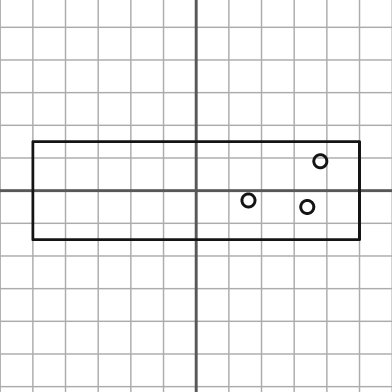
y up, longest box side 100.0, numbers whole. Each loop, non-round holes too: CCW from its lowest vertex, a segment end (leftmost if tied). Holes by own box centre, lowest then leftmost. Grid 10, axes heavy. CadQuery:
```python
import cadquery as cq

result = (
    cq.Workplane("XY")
    .moveTo(-50.0, -15.0)
    .lineTo(50.0, -15.0)
    .lineTo(50.0, 15.0)
    .lineTo(-50.0, 15.0)
    .close()
    .moveTo(34.0, -5.0)
    .circle(2.0)
    .moveTo(16.0, -3.0)
    .circle(2.0)
    .moveTo(38.0, 9.0)
    .circle(2.0)
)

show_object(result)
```